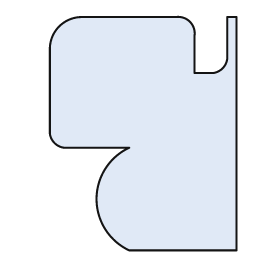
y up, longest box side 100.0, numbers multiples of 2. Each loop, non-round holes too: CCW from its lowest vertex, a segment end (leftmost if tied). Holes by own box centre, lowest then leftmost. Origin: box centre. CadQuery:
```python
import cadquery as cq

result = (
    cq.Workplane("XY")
    .moveTo(-6.0, -50.0)
    .lineTo(40.0, -50.0)
    .lineTo(40.0, 50.0)
    .lineTo(36.0, 50.0)
    .lineTo(36.0, 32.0)
    .threePointArc((34.0, 28.0), (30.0, 26.0))
    .lineTo(22.0, 26.0)
    .lineTo(22.0, 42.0)
    .threePointArc((20.0, 48.0), (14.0, 50.0))
    .lineTo(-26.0, 50.0)
    .threePointArc((-36.0, 46.0), (-40.0, 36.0))
    .lineTo(-40.0, 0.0)
    .threePointArc((-38.0, -4.0), (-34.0, -6.0))
    .lineTo(-6.0, -6.0)
    .threePointArc((-20.0, -28.0), (-6.0, -50.0))
    .close()
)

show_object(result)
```